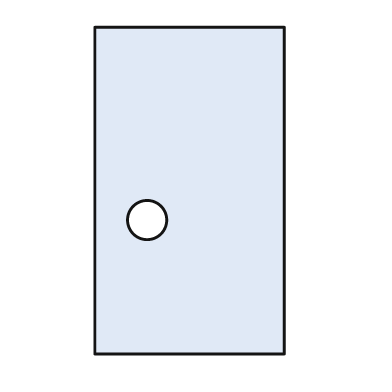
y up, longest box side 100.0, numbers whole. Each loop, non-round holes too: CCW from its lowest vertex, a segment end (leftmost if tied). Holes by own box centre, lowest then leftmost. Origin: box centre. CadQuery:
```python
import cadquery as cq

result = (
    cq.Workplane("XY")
    .moveTo(-29.0, -50.0)
    .lineTo(29.0, -50.0)
    .lineTo(29.0, 50.0)
    .lineTo(-29.0, 50.0)
    .close()
    .moveTo(-13.0, -9.0)
    .circle(6.0)
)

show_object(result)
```